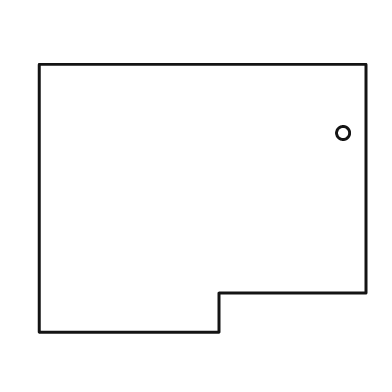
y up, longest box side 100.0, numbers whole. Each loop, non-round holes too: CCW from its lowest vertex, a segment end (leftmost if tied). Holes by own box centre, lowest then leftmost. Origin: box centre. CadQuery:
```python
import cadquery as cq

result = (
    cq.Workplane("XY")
    .moveTo(-50.0, -41.0)
    .lineTo(5.0, -41.0)
    .lineTo(5.0, -29.0)
    .lineTo(50.0, -29.0)
    .lineTo(50.0, 41.0)
    .lineTo(-50.0, 41.0)
    .close()
    .moveTo(43.0, 20.0)
    .circle(2.0)
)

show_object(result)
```